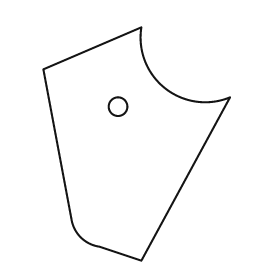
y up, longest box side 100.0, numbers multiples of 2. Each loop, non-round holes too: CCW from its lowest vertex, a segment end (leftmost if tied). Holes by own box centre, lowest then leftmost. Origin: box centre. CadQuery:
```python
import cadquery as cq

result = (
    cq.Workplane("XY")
    .moveTo(2.0, -50.0)
    .lineTo(40.0, 20.0)
    .threePointArc((12.0, 24.0), (2.0, 50.0))
    .lineTo(-40.0, 32.0)
    .lineTo(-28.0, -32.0)
    .threePointArc((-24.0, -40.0), (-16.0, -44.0))
    .close()
    .moveTo(-8.0, 16.0)
    .circle(4.0)
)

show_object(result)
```